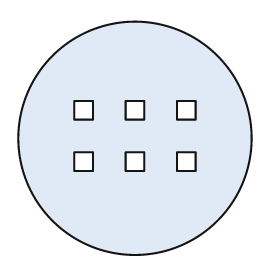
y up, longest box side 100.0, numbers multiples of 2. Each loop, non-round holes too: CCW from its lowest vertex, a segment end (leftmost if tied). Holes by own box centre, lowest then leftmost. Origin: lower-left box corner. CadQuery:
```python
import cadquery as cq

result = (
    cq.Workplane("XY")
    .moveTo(50.0, 50.0)
    .circle(50.0)
    .moveTo(24.0, 36.0)
    .lineTo(32.0, 36.0)
    .lineTo(32.0, 44.0)
    .lineTo(24.0, 44.0)
    .close()
    .moveTo(46.0, 36.0)
    .lineTo(54.0, 36.0)
    .lineTo(54.0, 44.0)
    .lineTo(46.0, 44.0)
    .close()
    .moveTo(68.0, 36.0)
    .lineTo(76.0, 36.0)
    .lineTo(76.0, 44.0)
    .lineTo(68.0, 44.0)
    .close()
    .moveTo(24.0, 58.0)
    .lineTo(32.0, 58.0)
    .lineTo(32.0, 66.0)
    .lineTo(24.0, 66.0)
    .close()
    .moveTo(46.0, 58.0)
    .lineTo(54.0, 58.0)
    .lineTo(54.0, 66.0)
    .lineTo(46.0, 66.0)
    .close()
    .moveTo(68.0, 58.0)
    .lineTo(76.0, 58.0)
    .lineTo(76.0, 66.0)
    .lineTo(68.0, 66.0)
    .close()
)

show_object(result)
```